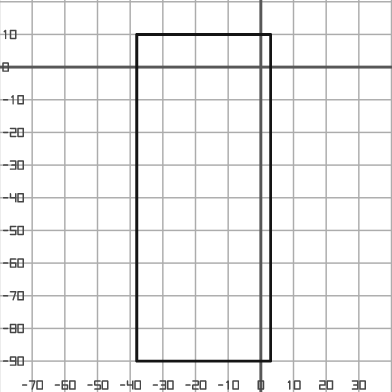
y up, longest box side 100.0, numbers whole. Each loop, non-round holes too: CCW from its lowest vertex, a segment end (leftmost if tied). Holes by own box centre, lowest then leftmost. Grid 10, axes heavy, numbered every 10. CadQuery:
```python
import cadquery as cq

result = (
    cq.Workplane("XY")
    .moveTo(-38.0, -90.0)
    .lineTo(3.0, -90.0)
    .lineTo(3.0, 10.0)
    .lineTo(-38.0, 10.0)
    .close()
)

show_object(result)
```